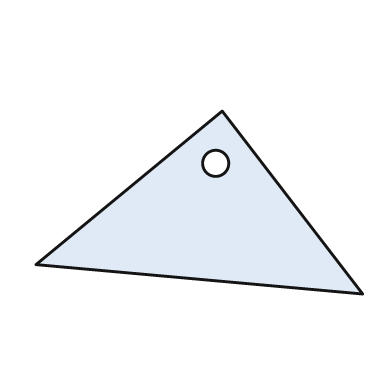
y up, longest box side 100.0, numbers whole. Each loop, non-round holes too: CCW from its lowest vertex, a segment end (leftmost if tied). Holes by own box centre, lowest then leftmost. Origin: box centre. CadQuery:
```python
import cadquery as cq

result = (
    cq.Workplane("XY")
    .moveTo(50.0, -28.0)
    .lineTo(7.0, 28.0)
    .lineTo(-50.0, -19.0)
    .close()
    .moveTo(5.0, 12.0)
    .circle(4.0)
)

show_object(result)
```